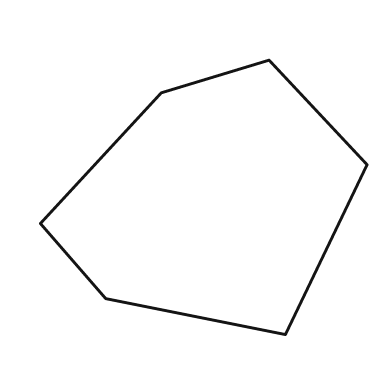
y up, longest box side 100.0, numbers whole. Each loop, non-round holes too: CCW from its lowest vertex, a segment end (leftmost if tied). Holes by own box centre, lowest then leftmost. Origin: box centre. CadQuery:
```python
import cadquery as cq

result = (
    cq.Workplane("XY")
    .moveTo(25.0, -42.0)
    .lineTo(50.0, 10.0)
    .lineTo(20.0, 42.0)
    .lineTo(-13.0, 32.0)
    .lineTo(-50.0, -8.0)
    .lineTo(-30.0, -31.0)
    .close()
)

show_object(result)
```